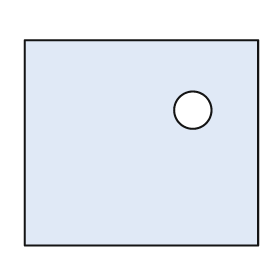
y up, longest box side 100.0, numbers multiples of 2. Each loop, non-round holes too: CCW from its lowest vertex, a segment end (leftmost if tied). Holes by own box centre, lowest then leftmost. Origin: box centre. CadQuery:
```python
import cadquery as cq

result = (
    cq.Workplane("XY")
    .moveTo(-50.0, -44.0)
    .lineTo(50.0, -44.0)
    .lineTo(50.0, 44.0)
    .lineTo(-50.0, 44.0)
    .close()
    .moveTo(22.0, 14.0)
    .circle(8.0)
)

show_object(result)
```